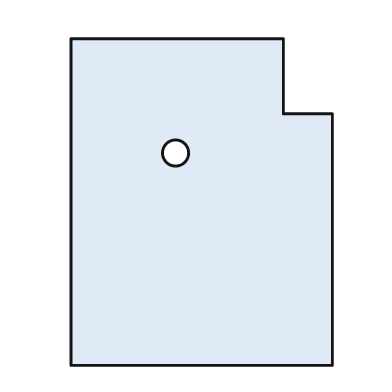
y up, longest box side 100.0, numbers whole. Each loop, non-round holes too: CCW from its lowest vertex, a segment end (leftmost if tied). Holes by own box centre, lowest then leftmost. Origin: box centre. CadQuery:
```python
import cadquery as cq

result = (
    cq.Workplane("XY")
    .moveTo(-40.0, -50.0)
    .lineTo(40.0, -50.0)
    .lineTo(40.0, 27.0)
    .lineTo(25.0, 27.0)
    .lineTo(25.0, 50.0)
    .lineTo(-40.0, 50.0)
    .close()
    .moveTo(-8.0, 15.0)
    .circle(4.0)
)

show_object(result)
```